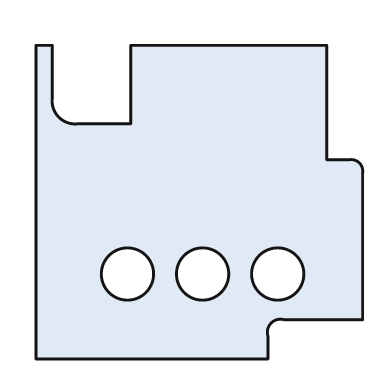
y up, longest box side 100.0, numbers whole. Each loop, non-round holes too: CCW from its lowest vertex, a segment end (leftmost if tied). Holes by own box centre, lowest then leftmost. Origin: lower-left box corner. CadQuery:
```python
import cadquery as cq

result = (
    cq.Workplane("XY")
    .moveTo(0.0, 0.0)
    .lineTo(71.0, 0.0)
    .lineTo(71.0, 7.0)
    .threePointArc((72.0, 11.0), (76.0, 12.0))
    .lineTo(100.0, 12.0)
    .lineTo(100.0, 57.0)
    .threePointArc((99.0, 60.0), (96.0, 61.0))
    .lineTo(89.0, 61.0)
    .lineTo(89.0, 96.0)
    .lineTo(29.0, 96.0)
    .lineTo(29.0, 72.0)
    .lineTo(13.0, 72.0)
    .threePointArc((7.0, 74.0), (5.0, 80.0))
    .lineTo(5.0, 96.0)
    .lineTo(0.0, 96.0)
    .close()
    .moveTo(28.0, 26.0)
    .circle(8.0)
    .moveTo(51.0, 26.0)
    .circle(8.0)
    .moveTo(74.0, 26.0)
    .circle(8.0)
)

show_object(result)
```